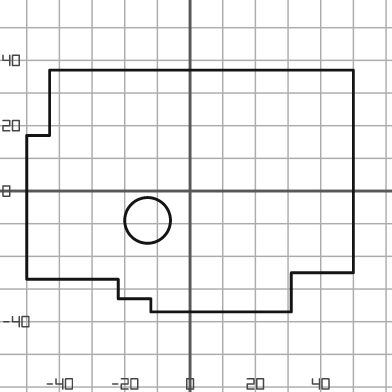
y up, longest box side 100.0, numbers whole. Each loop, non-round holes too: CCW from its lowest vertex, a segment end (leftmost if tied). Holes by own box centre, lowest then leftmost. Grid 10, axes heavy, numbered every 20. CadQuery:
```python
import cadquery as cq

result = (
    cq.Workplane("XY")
    .moveTo(-12.0, -37.0)
    .lineTo(31.0, -37.0)
    .lineTo(31.0, -25.0)
    .lineTo(50.0, -25.0)
    .lineTo(50.0, 37.0)
    .lineTo(-43.0, 37.0)
    .lineTo(-43.0, 17.0)
    .lineTo(-50.0, 17.0)
    .lineTo(-50.0, -27.0)
    .lineTo(-22.0, -27.0)
    .lineTo(-22.0, -33.0)
    .lineTo(-12.0, -33.0)
    .close()
    .moveTo(-13.0, -9.0)
    .circle(7.0)
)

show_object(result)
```